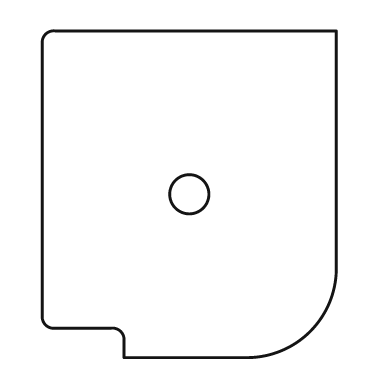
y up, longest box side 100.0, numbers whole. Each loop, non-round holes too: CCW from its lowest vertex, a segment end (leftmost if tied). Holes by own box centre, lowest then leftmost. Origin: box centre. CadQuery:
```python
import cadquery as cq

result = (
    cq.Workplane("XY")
    .moveTo(-20.0, -50.0)
    .lineTo(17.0, -50.0)
    .threePointArc((37.0, -42.0), (45.0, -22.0))
    .lineTo(45.0, 50.0)
    .lineTo(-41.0, 50.0)
    .threePointArc((-44.0, 49.0), (-45.0, 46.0))
    .lineTo(-45.0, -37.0)
    .threePointArc((-44.0, -40.0), (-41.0, -41.0))
    .lineTo(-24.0, -41.0)
    .threePointArc((-21.0, -42.0), (-20.0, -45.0))
    .close()
    .moveTo(0.0, 0.0)
    .circle(6.0)
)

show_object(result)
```